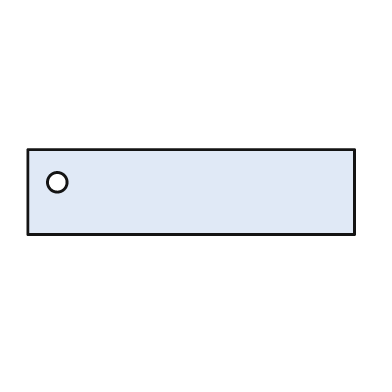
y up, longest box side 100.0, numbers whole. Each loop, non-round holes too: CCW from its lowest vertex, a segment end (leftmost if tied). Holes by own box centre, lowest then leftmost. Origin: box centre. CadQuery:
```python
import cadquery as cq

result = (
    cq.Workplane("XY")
    .moveTo(-50.0, -13.0)
    .lineTo(50.0, -13.0)
    .lineTo(50.0, 13.0)
    .lineTo(-50.0, 13.0)
    .close()
    .moveTo(-41.0, 3.0)
    .circle(3.0)
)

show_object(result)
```